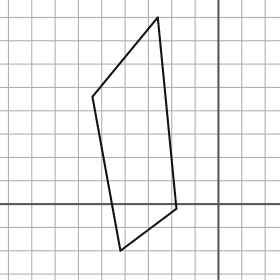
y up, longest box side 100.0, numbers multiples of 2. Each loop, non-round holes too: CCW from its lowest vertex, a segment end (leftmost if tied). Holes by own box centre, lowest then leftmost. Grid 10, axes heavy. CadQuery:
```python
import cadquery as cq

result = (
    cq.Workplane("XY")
    .moveTo(-42.0, -20.0)
    .lineTo(-18.0, -2.0)
    .lineTo(-26.0, 80.0)
    .lineTo(-54.0, 46.0)
    .close()
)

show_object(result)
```